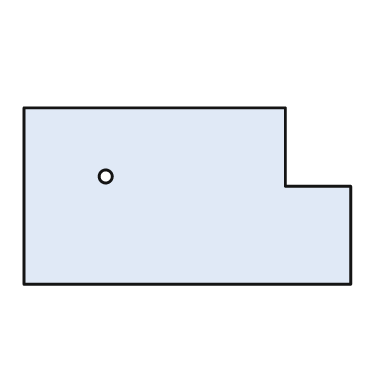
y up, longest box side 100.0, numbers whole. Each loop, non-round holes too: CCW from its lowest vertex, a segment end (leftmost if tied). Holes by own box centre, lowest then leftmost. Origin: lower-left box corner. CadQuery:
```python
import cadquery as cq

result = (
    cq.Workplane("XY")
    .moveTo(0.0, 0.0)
    .lineTo(100.0, 0.0)
    .lineTo(100.0, 30.0)
    .lineTo(80.0, 30.0)
    .lineTo(80.0, 54.0)
    .lineTo(0.0, 54.0)
    .close()
    .moveTo(25.0, 33.0)
    .circle(2.0)
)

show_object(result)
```